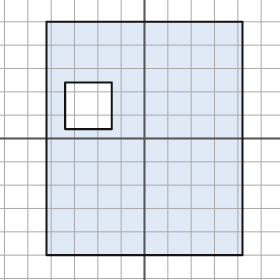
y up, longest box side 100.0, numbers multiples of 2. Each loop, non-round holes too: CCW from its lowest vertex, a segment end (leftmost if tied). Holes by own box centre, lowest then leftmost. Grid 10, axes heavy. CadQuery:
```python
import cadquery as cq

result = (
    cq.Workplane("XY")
    .moveTo(-42.0, -50.0)
    .lineTo(42.0, -50.0)
    .lineTo(42.0, 50.0)
    .lineTo(-42.0, 50.0)
    .close()
    .moveTo(-34.0, 4.0)
    .lineTo(-14.0, 4.0)
    .lineTo(-14.0, 24.0)
    .lineTo(-34.0, 24.0)
    .close()
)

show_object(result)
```